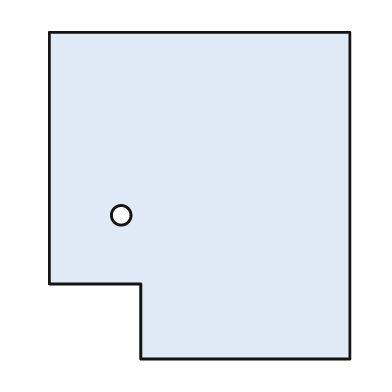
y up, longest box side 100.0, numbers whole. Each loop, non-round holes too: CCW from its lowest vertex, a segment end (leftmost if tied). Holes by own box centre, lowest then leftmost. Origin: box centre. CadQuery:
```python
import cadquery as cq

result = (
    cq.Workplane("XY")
    .moveTo(-18.0, -50.0)
    .lineTo(46.0, -50.0)
    .lineTo(46.0, 50.0)
    .lineTo(-46.0, 50.0)
    .lineTo(-46.0, -27.0)
    .lineTo(-18.0, -27.0)
    .close()
    .moveTo(-24.0, -6.0)
    .circle(3.0)
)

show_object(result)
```